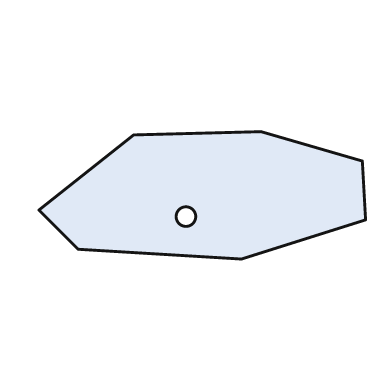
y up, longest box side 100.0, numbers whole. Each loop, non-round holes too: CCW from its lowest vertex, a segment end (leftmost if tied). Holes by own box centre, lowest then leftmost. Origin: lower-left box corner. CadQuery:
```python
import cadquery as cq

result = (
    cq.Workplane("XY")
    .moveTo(62.0, 0.0)
    .lineTo(100.0, 12.0)
    .lineTo(99.0, 30.0)
    .lineTo(68.0, 39.0)
    .lineTo(29.0, 38.0)
    .lineTo(0.0, 15.0)
    .lineTo(12.0, 3.0)
    .close()
    .moveTo(45.0, 13.0)
    .circle(3.0)
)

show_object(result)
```